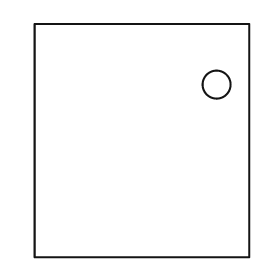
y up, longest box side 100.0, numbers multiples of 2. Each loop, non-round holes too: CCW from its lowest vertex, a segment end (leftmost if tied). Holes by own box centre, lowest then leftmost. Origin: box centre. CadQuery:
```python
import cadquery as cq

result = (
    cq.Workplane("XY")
    .moveTo(-46.0, -50.0)
    .lineTo(46.0, -50.0)
    .lineTo(46.0, 50.0)
    .lineTo(-46.0, 50.0)
    .close()
    .moveTo(32.0, 24.0)
    .circle(6.0)
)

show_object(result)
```